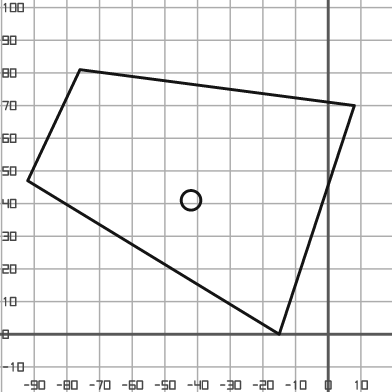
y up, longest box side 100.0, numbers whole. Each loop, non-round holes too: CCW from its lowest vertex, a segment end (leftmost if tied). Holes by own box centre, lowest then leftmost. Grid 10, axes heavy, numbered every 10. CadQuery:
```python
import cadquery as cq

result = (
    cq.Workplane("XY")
    .moveTo(-15.0, 0.0)
    .lineTo(8.0, 70.0)
    .lineTo(-76.0, 81.0)
    .lineTo(-92.0, 47.0)
    .close()
    .moveTo(-42.0, 41.0)
    .circle(3.0)
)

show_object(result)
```